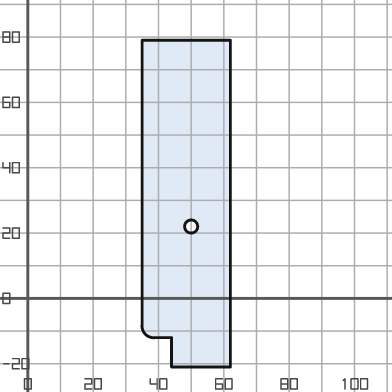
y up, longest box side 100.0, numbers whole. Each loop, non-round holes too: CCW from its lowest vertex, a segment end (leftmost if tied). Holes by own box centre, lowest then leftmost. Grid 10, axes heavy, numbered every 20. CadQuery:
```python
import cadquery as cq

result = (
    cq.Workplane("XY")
    .moveTo(44.0, -21.0)
    .lineTo(62.0, -21.0)
    .lineTo(62.0, 79.0)
    .lineTo(35.0, 79.0)
    .lineTo(35.0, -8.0)
    .threePointArc((36.0, -11.0), (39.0, -12.0))
    .lineTo(44.0, -12.0)
    .close()
    .moveTo(50.0, 22.0)
    .circle(2.0)
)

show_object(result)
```